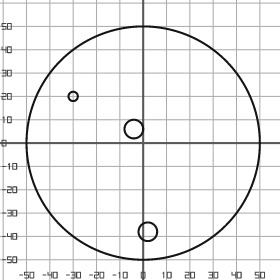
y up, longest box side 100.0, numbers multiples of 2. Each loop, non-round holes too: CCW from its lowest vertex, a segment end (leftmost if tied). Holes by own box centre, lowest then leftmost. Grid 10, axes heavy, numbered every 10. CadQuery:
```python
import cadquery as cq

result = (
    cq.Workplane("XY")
    .moveTo(0.0, 0.0)
    .circle(50.0)
    .moveTo(2.0, -38.0)
    .circle(4.0)
    .moveTo(-4.0, 6.0)
    .circle(4.0)
    .moveTo(-30.0, 20.0)
    .circle(2.0)
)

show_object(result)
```